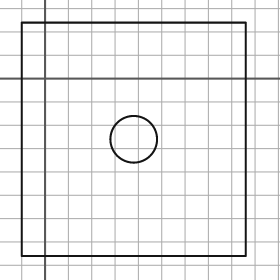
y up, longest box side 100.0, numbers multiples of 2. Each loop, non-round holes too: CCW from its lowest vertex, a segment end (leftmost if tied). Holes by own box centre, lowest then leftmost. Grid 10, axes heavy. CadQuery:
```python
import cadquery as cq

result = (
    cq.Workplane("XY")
    .moveTo(-10.0, -76.0)
    .lineTo(86.0, -76.0)
    .lineTo(86.0, 24.0)
    .lineTo(-10.0, 24.0)
    .close()
    .moveTo(38.0, -26.0)
    .circle(10.0)
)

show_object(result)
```